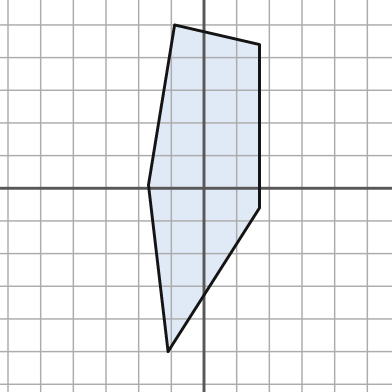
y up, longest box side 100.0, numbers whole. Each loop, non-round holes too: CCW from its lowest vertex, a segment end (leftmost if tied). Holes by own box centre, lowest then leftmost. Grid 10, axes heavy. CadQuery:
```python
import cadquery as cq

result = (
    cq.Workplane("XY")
    .moveTo(-11.0, -50.0)
    .lineTo(17.0, -6.0)
    .lineTo(17.0, 44.0)
    .lineTo(-9.0, 50.0)
    .lineTo(-17.0, 1.0)
    .close()
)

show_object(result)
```